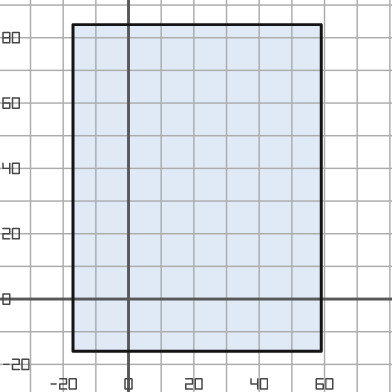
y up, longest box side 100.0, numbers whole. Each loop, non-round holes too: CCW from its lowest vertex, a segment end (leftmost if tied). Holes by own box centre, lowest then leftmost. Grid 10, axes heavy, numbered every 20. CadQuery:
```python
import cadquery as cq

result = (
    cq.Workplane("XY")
    .moveTo(-17.0, -16.0)
    .lineTo(59.0, -16.0)
    .lineTo(59.0, 84.0)
    .lineTo(-17.0, 84.0)
    .close()
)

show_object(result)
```